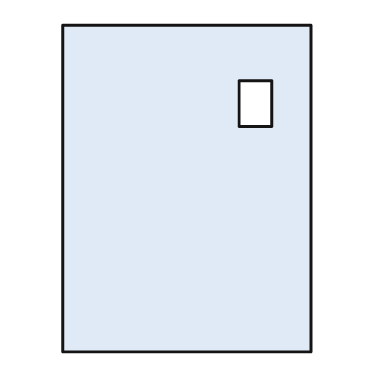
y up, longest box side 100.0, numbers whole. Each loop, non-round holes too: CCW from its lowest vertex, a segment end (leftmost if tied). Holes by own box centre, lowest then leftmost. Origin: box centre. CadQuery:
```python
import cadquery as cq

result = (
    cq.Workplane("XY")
    .moveTo(-38.0, -50.0)
    .lineTo(38.0, -50.0)
    .lineTo(38.0, 50.0)
    .lineTo(-38.0, 50.0)
    .close()
    .moveTo(16.0, 19.0)
    .lineTo(26.0, 19.0)
    .lineTo(26.0, 33.0)
    .lineTo(16.0, 33.0)
    .close()
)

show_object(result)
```